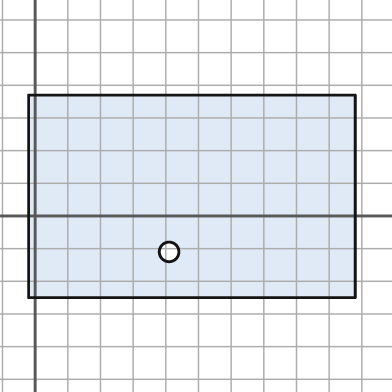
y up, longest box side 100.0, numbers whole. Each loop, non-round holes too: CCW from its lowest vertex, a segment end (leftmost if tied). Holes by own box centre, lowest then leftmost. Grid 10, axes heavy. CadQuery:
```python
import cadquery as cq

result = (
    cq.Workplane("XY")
    .moveTo(-2.0, -25.0)
    .lineTo(98.0, -25.0)
    .lineTo(98.0, 37.0)
    .lineTo(-2.0, 37.0)
    .close()
    .moveTo(41.0, -11.0)
    .circle(3.0)
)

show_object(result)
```